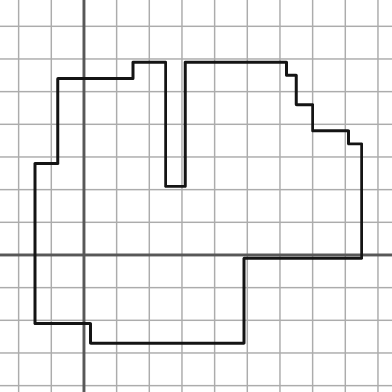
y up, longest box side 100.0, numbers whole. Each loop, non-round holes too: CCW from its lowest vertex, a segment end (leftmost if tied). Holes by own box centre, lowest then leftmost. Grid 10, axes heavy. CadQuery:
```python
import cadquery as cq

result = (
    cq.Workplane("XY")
    .moveTo(2.0, -27.0)
    .lineTo(49.0, -27.0)
    .lineTo(49.0, -1.0)
    .lineTo(85.0, -1.0)
    .lineTo(85.0, 34.0)
    .lineTo(81.0, 34.0)
    .lineTo(81.0, 38.0)
    .lineTo(70.0, 38.0)
    .lineTo(70.0, 46.0)
    .lineTo(65.0, 46.0)
    .lineTo(65.0, 55.0)
    .lineTo(62.0, 55.0)
    .lineTo(62.0, 59.0)
    .lineTo(31.0, 59.0)
    .lineTo(31.0, 21.0)
    .lineTo(25.0, 21.0)
    .lineTo(25.0, 59.0)
    .lineTo(15.0, 59.0)
    .lineTo(15.0, 54.0)
    .lineTo(-8.0, 54.0)
    .lineTo(-8.0, 28.0)
    .lineTo(-15.0, 28.0)
    .lineTo(-15.0, -21.0)
    .lineTo(2.0, -21.0)
    .close()
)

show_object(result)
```